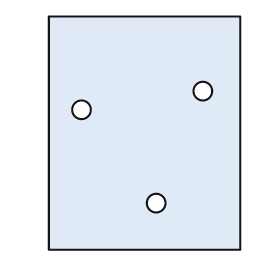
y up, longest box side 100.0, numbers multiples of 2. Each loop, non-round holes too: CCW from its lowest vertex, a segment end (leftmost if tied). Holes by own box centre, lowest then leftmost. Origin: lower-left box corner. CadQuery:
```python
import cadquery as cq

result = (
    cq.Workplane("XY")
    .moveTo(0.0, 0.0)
    .lineTo(82.0, 0.0)
    .lineTo(82.0, 100.0)
    .lineTo(0.0, 100.0)
    .close()
    .moveTo(46.0, 20.0)
    .circle(4.0)
    .moveTo(14.0, 60.0)
    .circle(4.0)
    .moveTo(66.0, 68.0)
    .circle(4.0)
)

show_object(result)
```